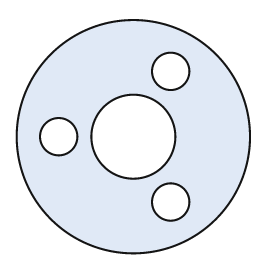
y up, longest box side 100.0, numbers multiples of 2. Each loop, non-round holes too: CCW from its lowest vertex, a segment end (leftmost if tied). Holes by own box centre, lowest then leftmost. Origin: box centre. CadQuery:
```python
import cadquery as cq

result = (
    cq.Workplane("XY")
    .moveTo(0.0, 0.0)
    .circle(50.0)
    .moveTo(16.0, -28.0)
    .circle(8.0)
    .moveTo(-32.0, 0.0)
    .circle(8.0)
    .moveTo(0.0, 0.0)
    .circle(18.0)
    .moveTo(16.0, 28.0)
    .circle(8.0)
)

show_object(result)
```